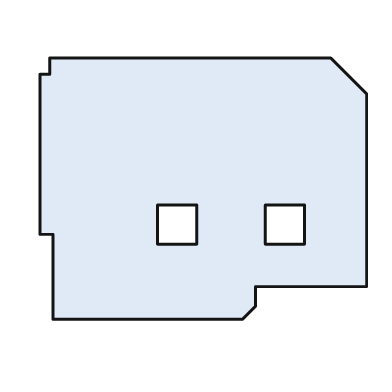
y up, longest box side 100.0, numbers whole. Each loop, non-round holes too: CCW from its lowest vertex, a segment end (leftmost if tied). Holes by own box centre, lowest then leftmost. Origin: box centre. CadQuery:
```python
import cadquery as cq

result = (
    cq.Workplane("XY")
    .moveTo(-46.0, -40.0)
    .lineTo(12.0, -40.0)
    .lineTo(16.0, -36.0)
    .lineTo(16.0, -30.0)
    .lineTo(50.0, -30.0)
    .lineTo(50.0, 29.0)
    .lineTo(39.0, 40.0)
    .lineTo(-47.0, 40.0)
    .lineTo(-47.0, 35.0)
    .lineTo(-50.0, 35.0)
    .lineTo(-50.0, -14.0)
    .lineTo(-46.0, -14.0)
    .close()
    .moveTo(-14.0, -17.0)
    .lineTo(-2.0, -17.0)
    .lineTo(-2.0, -5.0)
    .lineTo(-14.0, -5.0)
    .close()
    .moveTo(19.0, -17.0)
    .lineTo(31.0, -17.0)
    .lineTo(31.0, -5.0)
    .lineTo(19.0, -5.0)
    .close()
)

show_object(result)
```